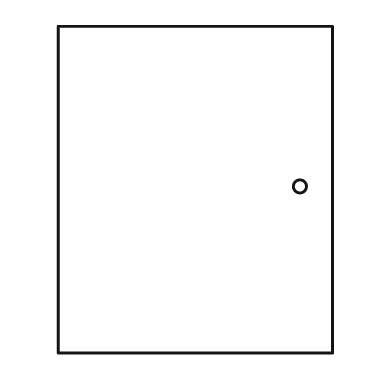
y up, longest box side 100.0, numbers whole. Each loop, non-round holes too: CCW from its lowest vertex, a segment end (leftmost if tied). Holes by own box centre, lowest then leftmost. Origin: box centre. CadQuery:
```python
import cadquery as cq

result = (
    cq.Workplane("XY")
    .moveTo(-42.0, -50.0)
    .lineTo(42.0, -50.0)
    .lineTo(42.0, 50.0)
    .lineTo(-42.0, 50.0)
    .close()
    .moveTo(32.0, 1.0)
    .circle(2.0)
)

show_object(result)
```